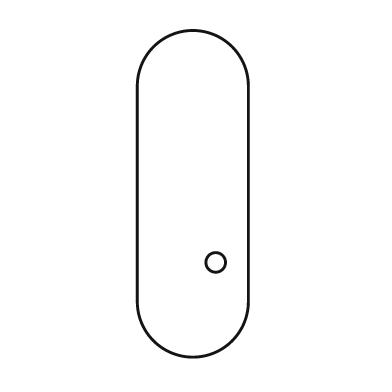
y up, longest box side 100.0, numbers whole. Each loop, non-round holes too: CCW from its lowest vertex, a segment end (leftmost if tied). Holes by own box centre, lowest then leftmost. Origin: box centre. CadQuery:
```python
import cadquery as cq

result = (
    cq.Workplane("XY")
    .moveTo(-17.0, -33.0)
    .threePointArc((0.0, -50.0), (17.0, -33.0))
    .lineTo(17.0, 33.0)
    .threePointArc((0.0, 50.0), (-17.0, 33.0))
    .close()
    .moveTo(7.0, -21.0)
    .circle(3.0)
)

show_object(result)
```